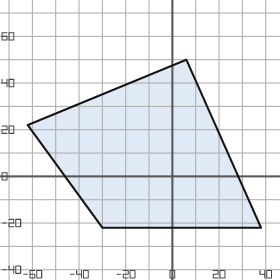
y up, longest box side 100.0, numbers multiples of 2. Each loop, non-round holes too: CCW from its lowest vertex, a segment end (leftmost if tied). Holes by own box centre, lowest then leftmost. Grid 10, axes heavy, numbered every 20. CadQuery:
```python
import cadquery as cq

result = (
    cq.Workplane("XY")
    .moveTo(-30.0, -22.0)
    .lineTo(38.0, -22.0)
    .lineTo(6.0, 50.0)
    .lineTo(-62.0, 22.0)
    .close()
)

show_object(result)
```